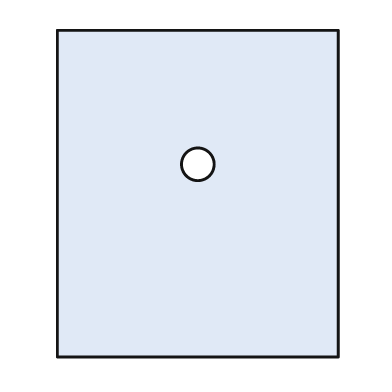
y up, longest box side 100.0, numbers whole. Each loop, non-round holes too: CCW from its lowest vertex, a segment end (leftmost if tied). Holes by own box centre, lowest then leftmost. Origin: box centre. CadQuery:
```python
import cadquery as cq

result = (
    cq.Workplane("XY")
    .moveTo(-43.0, -50.0)
    .lineTo(43.0, -50.0)
    .lineTo(43.0, 50.0)
    .lineTo(-43.0, 50.0)
    .close()
    .moveTo(0.0, 9.0)
    .circle(5.0)
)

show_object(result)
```